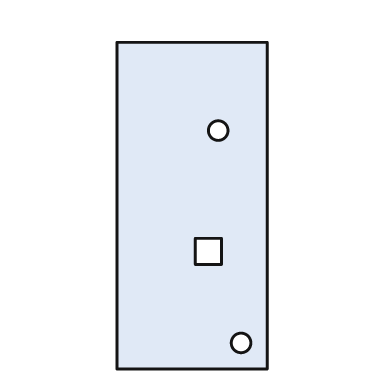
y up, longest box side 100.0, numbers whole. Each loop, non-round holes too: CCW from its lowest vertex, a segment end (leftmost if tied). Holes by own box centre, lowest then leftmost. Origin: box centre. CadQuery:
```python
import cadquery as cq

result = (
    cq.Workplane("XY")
    .moveTo(-23.0, -50.0)
    .lineTo(23.0, -50.0)
    .lineTo(23.0, 50.0)
    .lineTo(-23.0, 50.0)
    .close()
    .moveTo(15.0, -42.0)
    .circle(3.0)
    .moveTo(1.0, -18.0)
    .lineTo(9.0, -18.0)
    .lineTo(9.0, -10.0)
    .lineTo(1.0, -10.0)
    .close()
    .moveTo(8.0, 23.0)
    .circle(3.0)
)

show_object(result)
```